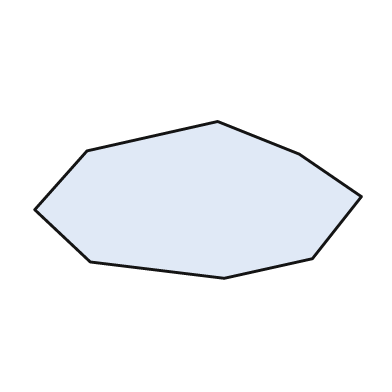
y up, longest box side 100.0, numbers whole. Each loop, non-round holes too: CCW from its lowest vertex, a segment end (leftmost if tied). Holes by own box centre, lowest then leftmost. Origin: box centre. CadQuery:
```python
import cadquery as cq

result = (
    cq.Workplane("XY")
    .moveTo(8.0, -24.0)
    .lineTo(35.0, -18.0)
    .lineTo(50.0, 1.0)
    .lineTo(31.0, 14.0)
    .lineTo(6.0, 24.0)
    .lineTo(-34.0, 15.0)
    .lineTo(-50.0, -3.0)
    .lineTo(-33.0, -19.0)
    .close()
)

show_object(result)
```